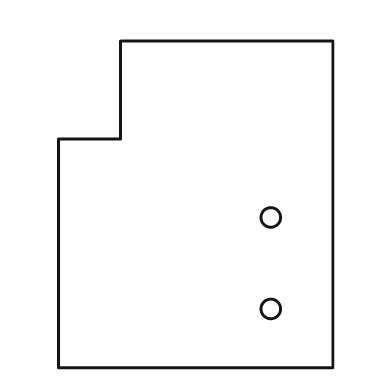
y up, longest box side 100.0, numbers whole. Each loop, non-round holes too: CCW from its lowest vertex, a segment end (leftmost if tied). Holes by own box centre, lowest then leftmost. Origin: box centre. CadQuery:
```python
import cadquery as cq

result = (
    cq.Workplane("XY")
    .moveTo(-42.0, -50.0)
    .lineTo(42.0, -50.0)
    .lineTo(42.0, 50.0)
    .lineTo(-23.0, 50.0)
    .lineTo(-23.0, 20.0)
    .lineTo(-42.0, 20.0)
    .close()
    .moveTo(23.0, -32.0)
    .circle(3.0)
    .moveTo(23.0, -4.0)
    .circle(3.0)
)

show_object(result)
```